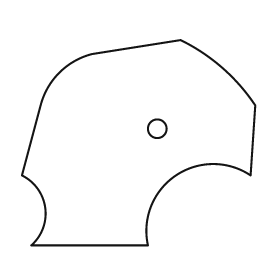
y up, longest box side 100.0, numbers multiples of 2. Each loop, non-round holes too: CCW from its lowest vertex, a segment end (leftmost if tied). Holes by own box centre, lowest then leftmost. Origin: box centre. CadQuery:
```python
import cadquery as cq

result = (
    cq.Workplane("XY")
    .moveTo(-46.0, -44.0)
    .lineTo(4.0, -44.0)
    .threePointArc((16.0, -14.0), (48.0, -14.0))
    .lineTo(50.0, 16.0)
    .threePointArc((36.0, 32.0), (18.0, 44.0))
    .lineTo(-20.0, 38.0)
    .threePointArc((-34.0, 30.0), (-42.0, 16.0))
    .lineTo(-50.0, -14.0)
    .threePointArc((-40.0, -28.0), (-46.0, -44.0))
    .close()
    .moveTo(8.0, 6.0)
    .circle(4.0)
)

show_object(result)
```